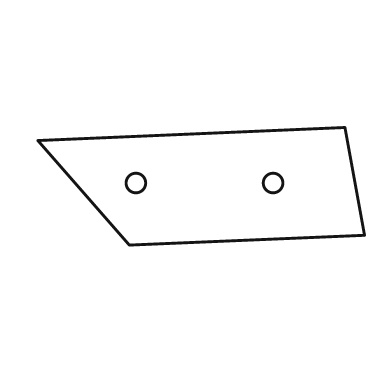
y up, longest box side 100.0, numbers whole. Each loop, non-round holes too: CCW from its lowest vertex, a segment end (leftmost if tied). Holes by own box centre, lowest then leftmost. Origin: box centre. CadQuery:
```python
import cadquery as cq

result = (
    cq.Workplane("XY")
    .moveTo(-22.0, -18.0)
    .lineTo(50.0, -15.0)
    .lineTo(44.0, 18.0)
    .lineTo(-50.0, 14.0)
    .close()
    .moveTo(-20.0, 1.0)
    .circle(3.0)
    .moveTo(22.0, 1.0)
    .circle(3.0)
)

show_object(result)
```